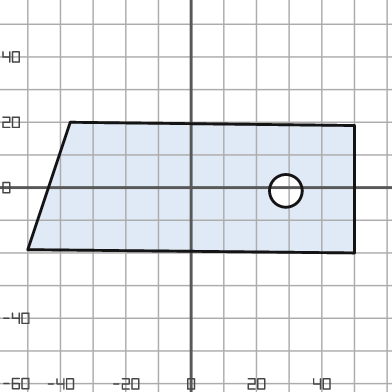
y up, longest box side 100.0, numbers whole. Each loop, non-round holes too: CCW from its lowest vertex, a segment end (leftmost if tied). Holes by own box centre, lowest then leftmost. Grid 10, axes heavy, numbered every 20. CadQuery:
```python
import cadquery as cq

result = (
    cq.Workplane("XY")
    .moveTo(50.0, -20.0)
    .lineTo(50.0, 19.0)
    .lineTo(-37.0, 20.0)
    .lineTo(-50.0, -19.0)
    .close()
    .moveTo(29.0, -1.0)
    .circle(5.0)
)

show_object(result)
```